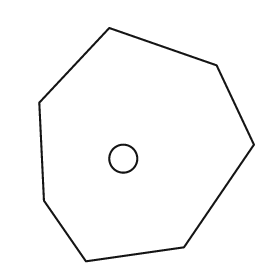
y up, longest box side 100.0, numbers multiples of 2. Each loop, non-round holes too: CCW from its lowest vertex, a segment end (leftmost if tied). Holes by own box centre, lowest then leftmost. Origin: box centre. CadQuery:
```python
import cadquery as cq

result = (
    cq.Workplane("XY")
    .moveTo(-26.0, -50.0)
    .lineTo(16.0, -44.0)
    .lineTo(46.0, 0.0)
    .lineTo(30.0, 34.0)
    .lineTo(-16.0, 50.0)
    .lineTo(-46.0, 18.0)
    .lineTo(-44.0, -24.0)
    .close()
    .moveTo(-10.0, -6.0)
    .circle(6.0)
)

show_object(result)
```